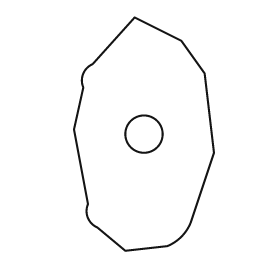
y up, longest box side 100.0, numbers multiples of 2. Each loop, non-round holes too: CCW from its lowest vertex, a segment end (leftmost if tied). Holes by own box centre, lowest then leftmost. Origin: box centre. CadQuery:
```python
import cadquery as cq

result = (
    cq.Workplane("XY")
    .moveTo(-8.0, -50.0)
    .lineTo(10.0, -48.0)
    .threePointArc((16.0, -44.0), (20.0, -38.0))
    .lineTo(30.0, -8.0)
    .lineTo(26.0, 26.0)
    .lineTo(16.0, 40.0)
    .lineTo(-4.0, 50.0)
    .lineTo(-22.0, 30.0)
    .threePointArc((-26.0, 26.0), (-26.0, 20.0))
    .lineTo(-30.0, 2.0)
    .lineTo(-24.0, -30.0)
    .threePointArc((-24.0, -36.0), (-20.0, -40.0))
    .close()
    .moveTo(0.0, 0.0)
    .circle(8.0)
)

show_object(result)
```